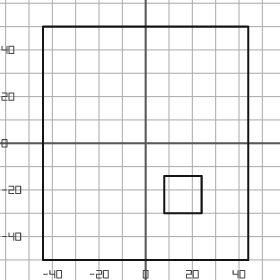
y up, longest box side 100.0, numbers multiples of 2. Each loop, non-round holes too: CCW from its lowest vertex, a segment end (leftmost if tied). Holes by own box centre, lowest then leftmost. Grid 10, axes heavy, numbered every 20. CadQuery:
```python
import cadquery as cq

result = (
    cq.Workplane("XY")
    .moveTo(-44.0, -50.0)
    .lineTo(44.0, -50.0)
    .lineTo(44.0, 50.0)
    .lineTo(-44.0, 50.0)
    .close()
    .moveTo(8.0, -30.0)
    .lineTo(24.0, -30.0)
    .lineTo(24.0, -14.0)
    .lineTo(8.0, -14.0)
    .close()
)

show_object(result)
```